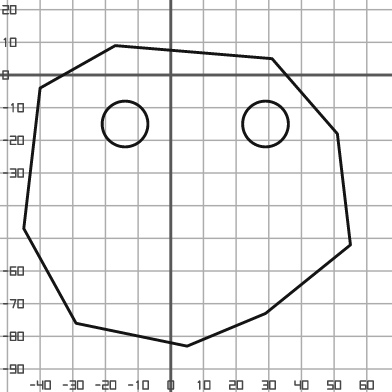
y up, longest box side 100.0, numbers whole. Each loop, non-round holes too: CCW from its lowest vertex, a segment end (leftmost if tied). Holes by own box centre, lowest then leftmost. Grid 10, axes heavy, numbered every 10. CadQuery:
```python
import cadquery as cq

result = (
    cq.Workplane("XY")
    .moveTo(5.0, -83.0)
    .lineTo(29.0, -73.0)
    .lineTo(55.0, -52.0)
    .lineTo(51.0, -18.0)
    .lineTo(31.0, 5.0)
    .lineTo(-17.0, 9.0)
    .lineTo(-40.0, -4.0)
    .lineTo(-45.0, -47.0)
    .lineTo(-29.0, -76.0)
    .close()
    .moveTo(-14.0, -15.0)
    .circle(7.0)
    .moveTo(29.0, -15.0)
    .circle(7.0)
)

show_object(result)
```